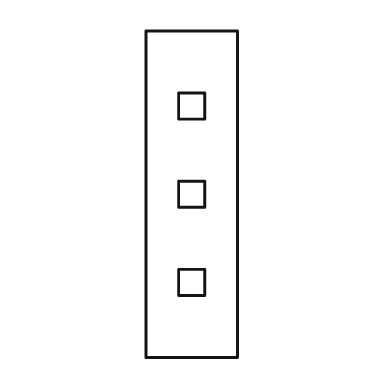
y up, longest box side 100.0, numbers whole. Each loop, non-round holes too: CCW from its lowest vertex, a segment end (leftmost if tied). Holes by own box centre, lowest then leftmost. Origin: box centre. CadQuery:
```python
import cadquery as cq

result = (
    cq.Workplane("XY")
    .moveTo(-14.0, -50.0)
    .lineTo(14.0, -50.0)
    .lineTo(14.0, 50.0)
    .lineTo(-14.0, 50.0)
    .close()
    .moveTo(-4.0, -31.0)
    .lineTo(4.0, -31.0)
    .lineTo(4.0, -23.0)
    .lineTo(-4.0, -23.0)
    .close()
    .moveTo(-4.0, -4.0)
    .lineTo(4.0, -4.0)
    .lineTo(4.0, 4.0)
    .lineTo(-4.0, 4.0)
    .close()
    .moveTo(-4.0, 23.0)
    .lineTo(4.0, 23.0)
    .lineTo(4.0, 31.0)
    .lineTo(-4.0, 31.0)
    .close()
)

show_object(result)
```